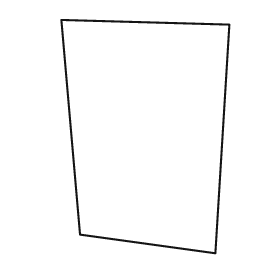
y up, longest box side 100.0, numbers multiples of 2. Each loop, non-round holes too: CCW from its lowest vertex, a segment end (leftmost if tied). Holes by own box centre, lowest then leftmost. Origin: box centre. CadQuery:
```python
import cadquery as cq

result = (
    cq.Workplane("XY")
    .moveTo(30.0, -50.0)
    .lineTo(36.0, 48.0)
    .lineTo(-36.0, 50.0)
    .lineTo(-28.0, -42.0)
    .close()
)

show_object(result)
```